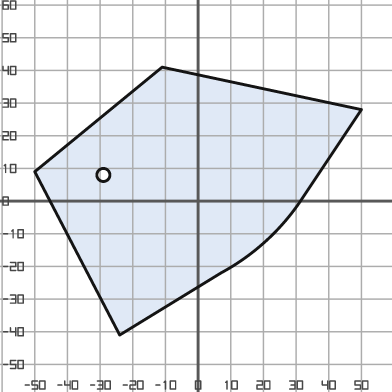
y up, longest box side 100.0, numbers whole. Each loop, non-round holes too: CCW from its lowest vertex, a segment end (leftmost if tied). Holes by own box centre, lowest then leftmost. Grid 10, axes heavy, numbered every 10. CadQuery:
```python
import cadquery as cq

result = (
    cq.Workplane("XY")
    .moveTo(-24.0, -41.0)
    .lineTo(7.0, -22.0)
    .threePointArc((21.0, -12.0), (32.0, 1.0))
    .lineTo(50.0, 28.0)
    .lineTo(-11.0, 41.0)
    .lineTo(-50.0, 9.0)
    .close()
    .moveTo(-29.0, 8.0)
    .circle(2.0)
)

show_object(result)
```